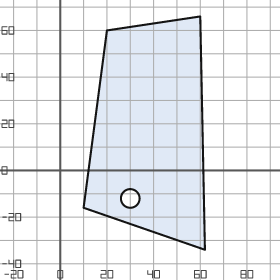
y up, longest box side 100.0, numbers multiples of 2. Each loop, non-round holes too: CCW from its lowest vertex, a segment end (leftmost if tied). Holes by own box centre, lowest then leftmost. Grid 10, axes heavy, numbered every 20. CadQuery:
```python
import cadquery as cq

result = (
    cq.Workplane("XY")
    .moveTo(62.0, -34.0)
    .lineTo(60.0, 66.0)
    .lineTo(20.0, 60.0)
    .lineTo(10.0, -16.0)
    .close()
    .moveTo(30.0, -12.0)
    .circle(4.0)
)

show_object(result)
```